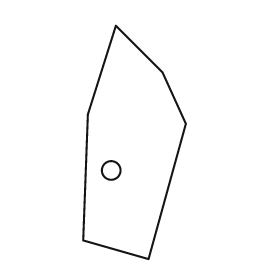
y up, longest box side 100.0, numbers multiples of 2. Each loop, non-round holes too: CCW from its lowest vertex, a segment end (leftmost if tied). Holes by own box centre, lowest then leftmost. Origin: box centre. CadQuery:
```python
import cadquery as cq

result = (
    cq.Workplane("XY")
    .moveTo(6.0, -50.0)
    .lineTo(22.0, 8.0)
    .lineTo(12.0, 30.0)
    .lineTo(-8.0, 50.0)
    .lineTo(-20.0, 12.0)
    .lineTo(-22.0, -42.0)
    .close()
    .moveTo(-10.0, -12.0)
    .circle(4.0)
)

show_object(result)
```